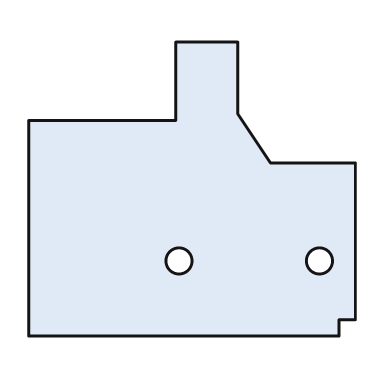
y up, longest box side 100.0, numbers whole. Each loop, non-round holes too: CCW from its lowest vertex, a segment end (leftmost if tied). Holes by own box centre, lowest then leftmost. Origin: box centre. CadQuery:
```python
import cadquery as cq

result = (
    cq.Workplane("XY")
    .moveTo(-50.0, -45.0)
    .lineTo(45.0, -45.0)
    .lineTo(45.0, -40.0)
    .lineTo(50.0, -40.0)
    .lineTo(50.0, 8.0)
    .lineTo(24.0, 8.0)
    .lineTo(14.0, 23.0)
    .lineTo(14.0, 45.0)
    .lineTo(-5.0, 45.0)
    .lineTo(-5.0, 21.0)
    .lineTo(-50.0, 21.0)
    .close()
    .moveTo(-4.0, -22.0)
    .circle(4.0)
    .moveTo(39.0, -22.0)
    .circle(4.0)
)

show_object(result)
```